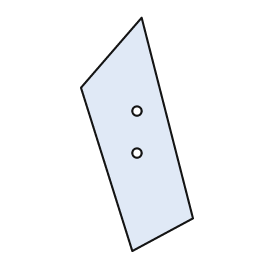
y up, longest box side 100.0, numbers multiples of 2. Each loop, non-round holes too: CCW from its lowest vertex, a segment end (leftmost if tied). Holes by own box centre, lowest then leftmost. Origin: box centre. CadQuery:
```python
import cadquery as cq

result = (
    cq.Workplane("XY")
    .moveTo(-2.0, -50.0)
    .lineTo(24.0, -36.0)
    .lineTo(2.0, 50.0)
    .lineTo(-24.0, 20.0)
    .close()
    .moveTo(0.0, -8.0)
    .circle(2.0)
    .moveTo(0.0, 10.0)
    .circle(2.0)
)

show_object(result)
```